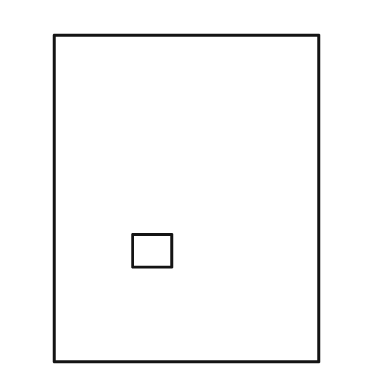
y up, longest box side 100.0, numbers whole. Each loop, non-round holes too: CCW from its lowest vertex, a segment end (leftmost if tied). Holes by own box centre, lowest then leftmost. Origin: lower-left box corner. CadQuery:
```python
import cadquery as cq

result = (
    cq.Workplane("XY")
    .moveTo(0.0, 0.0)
    .lineTo(81.0, 0.0)
    .lineTo(81.0, 100.0)
    .lineTo(0.0, 100.0)
    .close()
    .moveTo(24.0, 29.0)
    .lineTo(36.0, 29.0)
    .lineTo(36.0, 39.0)
    .lineTo(24.0, 39.0)
    .close()
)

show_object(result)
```